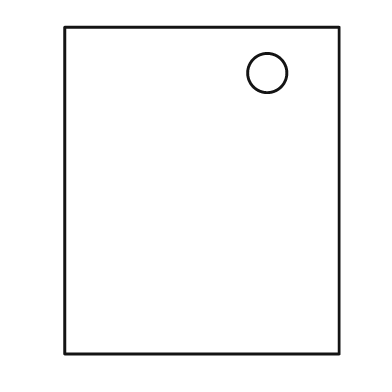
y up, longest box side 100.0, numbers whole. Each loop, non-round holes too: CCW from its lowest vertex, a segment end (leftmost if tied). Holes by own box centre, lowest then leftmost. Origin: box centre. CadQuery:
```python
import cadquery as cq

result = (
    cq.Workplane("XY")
    .moveTo(-42.0, -50.0)
    .lineTo(42.0, -50.0)
    .lineTo(42.0, 50.0)
    .lineTo(-42.0, 50.0)
    .close()
    .moveTo(20.0, 36.0)
    .circle(6.0)
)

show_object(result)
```